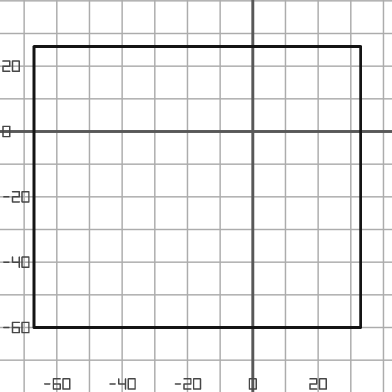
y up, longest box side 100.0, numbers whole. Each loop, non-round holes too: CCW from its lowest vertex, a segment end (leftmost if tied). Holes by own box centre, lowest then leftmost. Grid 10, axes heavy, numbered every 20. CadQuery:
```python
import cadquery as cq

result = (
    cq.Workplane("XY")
    .moveTo(-67.0, -60.0)
    .lineTo(33.0, -60.0)
    .lineTo(33.0, 26.0)
    .lineTo(-67.0, 26.0)
    .close()
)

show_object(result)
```